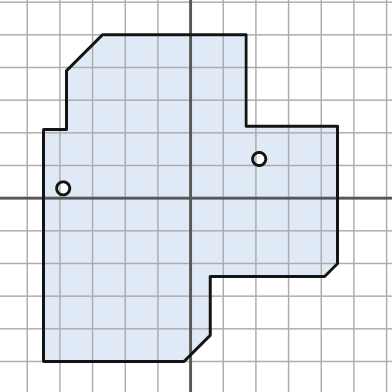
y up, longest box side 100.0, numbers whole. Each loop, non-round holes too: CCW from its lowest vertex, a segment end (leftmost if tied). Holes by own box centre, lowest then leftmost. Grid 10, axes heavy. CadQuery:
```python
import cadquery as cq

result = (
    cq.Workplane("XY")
    .moveTo(-45.0, -50.0)
    .lineTo(-2.0, -50.0)
    .lineTo(6.0, -42.0)
    .lineTo(6.0, -24.0)
    .lineTo(41.0, -24.0)
    .lineTo(45.0, -20.0)
    .lineTo(45.0, 22.0)
    .lineTo(17.0, 22.0)
    .lineTo(17.0, 50.0)
    .lineTo(-27.0, 50.0)
    .lineTo(-38.0, 39.0)
    .lineTo(-38.0, 21.0)
    .lineTo(-45.0, 21.0)
    .close()
    .moveTo(-39.0, 3.0)
    .circle(2.0)
    .moveTo(21.0, 12.0)
    .circle(2.0)
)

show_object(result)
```